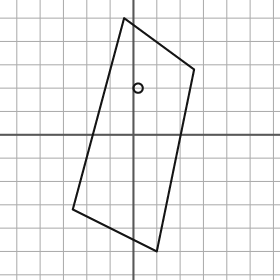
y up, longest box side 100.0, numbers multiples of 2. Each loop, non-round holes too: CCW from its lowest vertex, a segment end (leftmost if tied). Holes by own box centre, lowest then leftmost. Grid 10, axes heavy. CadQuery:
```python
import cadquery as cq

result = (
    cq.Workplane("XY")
    .moveTo(10.0, -50.0)
    .lineTo(26.0, 28.0)
    .lineTo(-4.0, 50.0)
    .lineTo(-26.0, -32.0)
    .close()
    .moveTo(2.0, 20.0)
    .circle(2.0)
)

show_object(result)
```